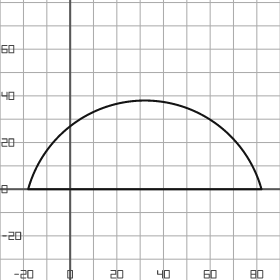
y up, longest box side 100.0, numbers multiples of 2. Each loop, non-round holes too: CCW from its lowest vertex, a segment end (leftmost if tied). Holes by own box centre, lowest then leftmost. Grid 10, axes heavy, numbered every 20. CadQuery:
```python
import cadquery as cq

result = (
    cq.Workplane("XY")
    .moveTo(-18.0, 0.0)
    .lineTo(82.0, 0.0)
    .threePointArc((32.0, 38.0), (-18.0, 0.0))
    .close()
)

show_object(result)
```